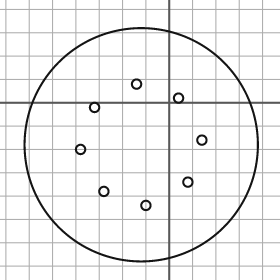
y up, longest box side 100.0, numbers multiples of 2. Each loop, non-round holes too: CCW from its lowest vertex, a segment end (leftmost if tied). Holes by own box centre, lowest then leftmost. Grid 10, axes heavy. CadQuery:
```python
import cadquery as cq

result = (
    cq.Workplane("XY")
    .moveTo(-12.0, -18.0)
    .circle(50.0)
    .moveTo(-10.0, -44.0)
    .circle(2.0)
    .moveTo(-28.0, -38.0)
    .circle(2.0)
    .moveTo(8.0, -34.0)
    .circle(2.0)
    .moveTo(-38.0, -20.0)
    .circle(2.0)
    .moveTo(14.0, -16.0)
    .circle(2.0)
    .moveTo(-32.0, -2.0)
    .circle(2.0)
    .moveTo(4.0, 2.0)
    .circle(2.0)
    .moveTo(-14.0, 8.0)
    .circle(2.0)
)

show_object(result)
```